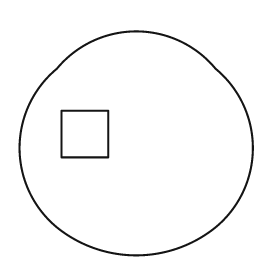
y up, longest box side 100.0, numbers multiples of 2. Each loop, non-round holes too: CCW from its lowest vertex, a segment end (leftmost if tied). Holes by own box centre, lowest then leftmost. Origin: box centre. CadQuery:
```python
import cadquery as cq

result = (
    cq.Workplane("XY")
    .moveTo(-34.0, -36.0)
    .threePointArc((0.0, -48.0), (34.0, -36.0))
    .threePointArc((50.0, -2.0), (34.0, 32.0))
    .threePointArc((0.0, 48.0), (-34.0, 32.0))
    .threePointArc((-50.0, -2.0), (-34.0, -36.0))
    .close()
    .moveTo(-32.0, -6.0)
    .lineTo(-12.0, -6.0)
    .lineTo(-12.0, 14.0)
    .lineTo(-32.0, 14.0)
    .close()
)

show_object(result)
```